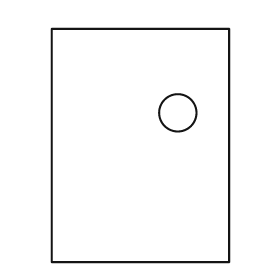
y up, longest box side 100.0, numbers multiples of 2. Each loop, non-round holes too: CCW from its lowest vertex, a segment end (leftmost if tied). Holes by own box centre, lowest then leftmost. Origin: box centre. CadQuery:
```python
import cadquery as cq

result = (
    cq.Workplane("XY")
    .moveTo(-38.0, -50.0)
    .lineTo(38.0, -50.0)
    .lineTo(38.0, 50.0)
    .lineTo(-38.0, 50.0)
    .close()
    .moveTo(16.0, 14.0)
    .circle(8.0)
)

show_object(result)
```